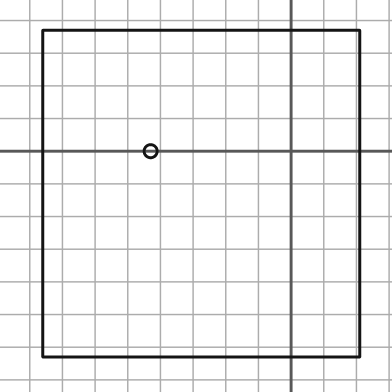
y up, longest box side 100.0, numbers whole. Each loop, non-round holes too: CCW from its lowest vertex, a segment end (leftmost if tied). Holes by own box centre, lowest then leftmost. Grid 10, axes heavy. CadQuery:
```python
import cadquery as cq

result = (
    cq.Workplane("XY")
    .moveTo(-76.0, -63.0)
    .lineTo(21.0, -63.0)
    .lineTo(21.0, 37.0)
    .lineTo(-76.0, 37.0)
    .close()
    .moveTo(-43.0, 0.0)
    .circle(2.0)
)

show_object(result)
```